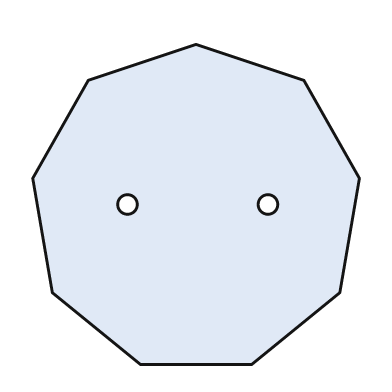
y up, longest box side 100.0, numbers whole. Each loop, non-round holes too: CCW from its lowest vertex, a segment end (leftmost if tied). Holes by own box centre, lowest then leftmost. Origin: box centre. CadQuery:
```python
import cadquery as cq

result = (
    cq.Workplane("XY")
    .moveTo(-17.0, -49.0)
    .lineTo(17.0, -49.0)
    .lineTo(44.0, -27.0)
    .lineTo(50.0, 8.0)
    .lineTo(33.0, 38.0)
    .lineTo(0.0, 49.0)
    .lineTo(-33.0, 38.0)
    .lineTo(-50.0, 8.0)
    .lineTo(-44.0, -27.0)
    .close()
    .moveTo(-21.0, 0.0)
    .circle(3.0)
    .moveTo(22.0, 0.0)
    .circle(3.0)
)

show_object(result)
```